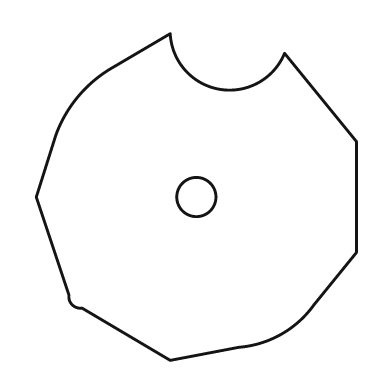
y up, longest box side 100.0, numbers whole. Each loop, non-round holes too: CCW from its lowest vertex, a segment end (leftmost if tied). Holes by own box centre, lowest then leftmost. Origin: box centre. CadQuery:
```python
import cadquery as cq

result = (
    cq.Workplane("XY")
    .moveTo(-8.0, -50.0)
    .lineTo(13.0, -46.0)
    .threePointArc((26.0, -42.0), (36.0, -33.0))
    .lineTo(49.0, -17.0)
    .lineTo(49.0, 17.0)
    .lineTo(27.0, 44.0)
    .threePointArc((7.0, 33.0), (-8.0, 50.0))
    .lineTo(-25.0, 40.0)
    .threePointArc((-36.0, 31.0), (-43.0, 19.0))
    .lineTo(-49.0, 0.0)
    .lineTo(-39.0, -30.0)
    .threePointArc((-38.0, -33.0), (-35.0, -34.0))
    .close()
    .moveTo(0.0, 0.0)
    .circle(6.0)
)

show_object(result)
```